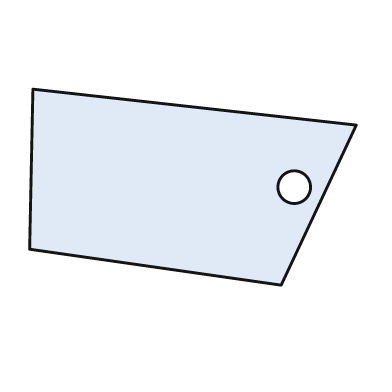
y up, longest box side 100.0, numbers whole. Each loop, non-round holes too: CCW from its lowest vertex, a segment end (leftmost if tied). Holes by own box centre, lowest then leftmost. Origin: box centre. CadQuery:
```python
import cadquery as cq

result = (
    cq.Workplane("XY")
    .moveTo(27.0, -30.0)
    .lineTo(50.0, 19.0)
    .lineTo(-49.0, 30.0)
    .lineTo(-50.0, -19.0)
    .close()
    .moveTo(31.0, 0.0)
    .circle(5.0)
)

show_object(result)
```